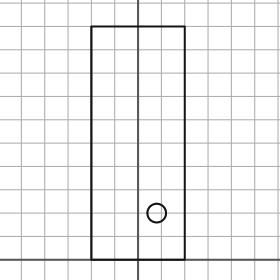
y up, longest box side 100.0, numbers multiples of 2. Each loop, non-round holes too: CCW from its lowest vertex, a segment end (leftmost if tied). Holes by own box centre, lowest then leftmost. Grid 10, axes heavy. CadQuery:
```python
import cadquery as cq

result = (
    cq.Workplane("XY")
    .moveTo(-20.0, 0.0)
    .lineTo(20.0, 0.0)
    .lineTo(20.0, 100.0)
    .lineTo(-20.0, 100.0)
    .close()
    .moveTo(8.0, 20.0)
    .circle(4.0)
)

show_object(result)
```